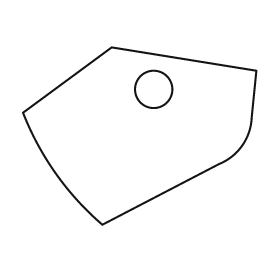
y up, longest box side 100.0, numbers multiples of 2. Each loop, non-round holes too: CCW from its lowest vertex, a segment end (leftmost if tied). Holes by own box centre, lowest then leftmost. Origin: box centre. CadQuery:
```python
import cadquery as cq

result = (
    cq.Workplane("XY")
    .moveTo(-16.0, -38.0)
    .lineTo(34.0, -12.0)
    .threePointArc((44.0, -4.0), (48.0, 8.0))
    .lineTo(50.0, 28.0)
    .lineTo(-12.0, 38.0)
    .lineTo(-50.0, 10.0)
    .threePointArc((-36.0, -16.0), (-16.0, -38.0))
    .close()
    .moveTo(6.0, 20.0)
    .circle(8.0)
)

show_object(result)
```